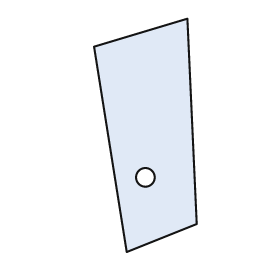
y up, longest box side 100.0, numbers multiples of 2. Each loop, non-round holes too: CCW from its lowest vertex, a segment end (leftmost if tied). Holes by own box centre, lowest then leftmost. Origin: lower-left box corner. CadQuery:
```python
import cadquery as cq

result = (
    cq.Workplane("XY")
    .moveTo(14.0, 0.0)
    .lineTo(44.0, 12.0)
    .lineTo(40.0, 100.0)
    .lineTo(0.0, 88.0)
    .close()
    .moveTo(22.0, 32.0)
    .circle(4.0)
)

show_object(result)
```